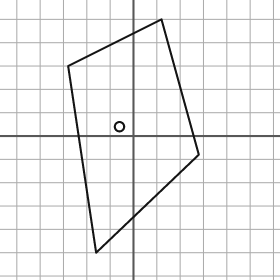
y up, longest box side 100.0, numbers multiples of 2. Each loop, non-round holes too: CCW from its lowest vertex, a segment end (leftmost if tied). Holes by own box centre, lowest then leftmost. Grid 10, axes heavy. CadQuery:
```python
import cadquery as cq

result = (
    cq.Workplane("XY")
    .moveTo(-16.0, -50.0)
    .lineTo(28.0, -8.0)
    .lineTo(12.0, 50.0)
    .lineTo(-28.0, 30.0)
    .close()
    .moveTo(-6.0, 4.0)
    .circle(2.0)
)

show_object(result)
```